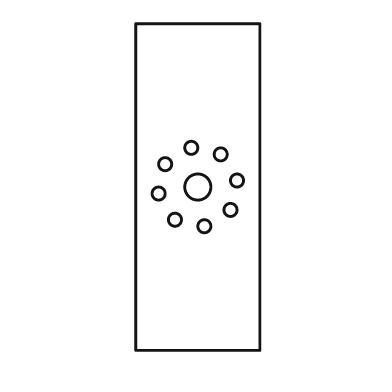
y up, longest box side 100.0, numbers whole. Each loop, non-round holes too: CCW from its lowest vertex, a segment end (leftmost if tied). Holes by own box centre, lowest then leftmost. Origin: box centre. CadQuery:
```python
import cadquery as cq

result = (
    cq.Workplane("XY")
    .moveTo(-19.0, -50.0)
    .lineTo(19.0, -50.0)
    .lineTo(19.0, 50.0)
    .lineTo(-19.0, 50.0)
    .close()
    .moveTo(2.0, -12.0)
    .circle(2.0)
    .moveTo(-7.0, -10.0)
    .circle(2.0)
    .moveTo(10.0, -7.0)
    .circle(2.0)
    .moveTo(-12.0, -2.0)
    .circle(2.0)
    .moveTo(0.0, 0.0)
    .circle(4.0)
    .moveTo(12.0, 2.0)
    .circle(2.0)
    .moveTo(-10.0, 7.0)
    .circle(2.0)
    .moveTo(7.0, 10.0)
    .circle(2.0)
    .moveTo(-2.0, 12.0)
    .circle(2.0)
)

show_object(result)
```